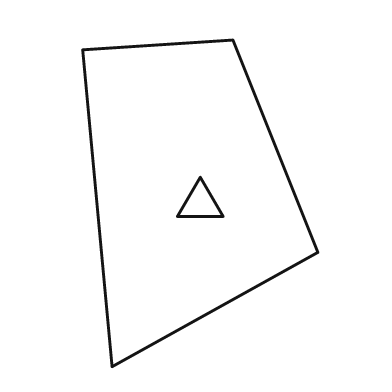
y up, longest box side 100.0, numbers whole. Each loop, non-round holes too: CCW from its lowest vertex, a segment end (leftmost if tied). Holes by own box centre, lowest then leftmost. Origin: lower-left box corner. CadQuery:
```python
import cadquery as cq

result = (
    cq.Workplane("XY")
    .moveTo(9.0, 0.0)
    .lineTo(72.0, 35.0)
    .lineTo(46.0, 100.0)
    .lineTo(0.0, 97.0)
    .close()
    .moveTo(29.0, 46.0)
    .lineTo(43.0, 46.0)
    .lineTo(36.0, 58.0)
    .close()
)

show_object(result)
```